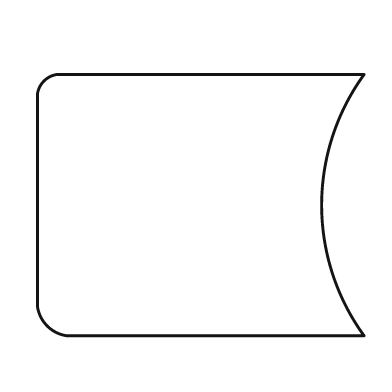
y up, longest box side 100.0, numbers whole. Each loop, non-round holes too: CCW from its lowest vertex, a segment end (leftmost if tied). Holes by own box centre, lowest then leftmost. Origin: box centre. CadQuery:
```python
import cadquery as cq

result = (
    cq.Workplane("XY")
    .moveTo(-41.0, -40.0)
    .lineTo(50.0, -40.0)
    .threePointArc((37.0, 0.0), (50.0, 40.0))
    .lineTo(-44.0, 40.0)
    .threePointArc((-48.0, 38.0), (-50.0, 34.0))
    .lineTo(-50.0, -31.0)
    .threePointArc((-47.0, -37.0), (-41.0, -40.0))
    .close()
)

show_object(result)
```